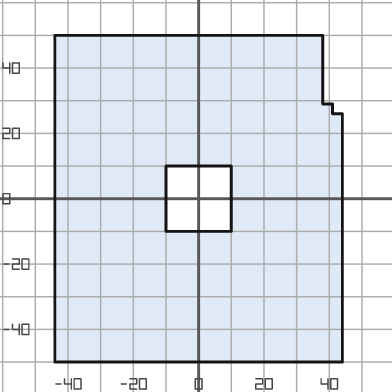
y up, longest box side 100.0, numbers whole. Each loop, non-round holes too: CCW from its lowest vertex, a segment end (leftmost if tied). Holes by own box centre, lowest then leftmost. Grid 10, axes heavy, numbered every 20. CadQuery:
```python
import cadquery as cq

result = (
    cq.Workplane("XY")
    .moveTo(-44.0, -50.0)
    .lineTo(44.0, -50.0)
    .lineTo(44.0, 26.0)
    .lineTo(41.0, 26.0)
    .lineTo(41.0, 29.0)
    .lineTo(38.0, 29.0)
    .lineTo(38.0, 50.0)
    .lineTo(-44.0, 50.0)
    .close()
    .moveTo(-10.0, -10.0)
    .lineTo(10.0, -10.0)
    .lineTo(10.0, 10.0)
    .lineTo(-10.0, 10.0)
    .close()
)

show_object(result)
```